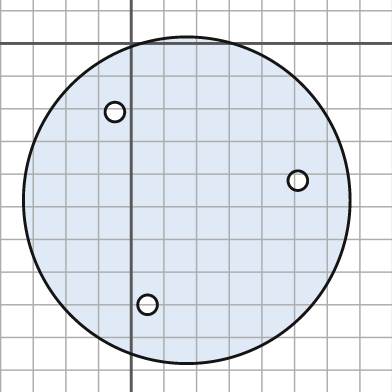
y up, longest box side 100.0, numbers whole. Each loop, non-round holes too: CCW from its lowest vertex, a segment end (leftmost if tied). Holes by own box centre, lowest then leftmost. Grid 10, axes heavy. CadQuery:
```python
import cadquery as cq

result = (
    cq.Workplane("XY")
    .moveTo(17.0, -48.0)
    .circle(50.0)
    .moveTo(5.0, -80.0)
    .circle(3.0)
    .moveTo(51.0, -42.0)
    .circle(3.0)
    .moveTo(-5.0, -21.0)
    .circle(3.0)
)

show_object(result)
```